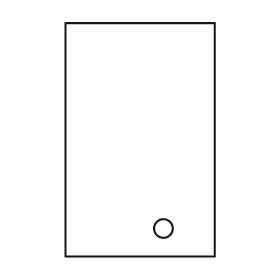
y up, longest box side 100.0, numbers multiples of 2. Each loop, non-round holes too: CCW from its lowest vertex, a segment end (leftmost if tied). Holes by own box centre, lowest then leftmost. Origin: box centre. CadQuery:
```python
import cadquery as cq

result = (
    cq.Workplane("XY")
    .moveTo(-32.0, -50.0)
    .lineTo(32.0, -50.0)
    .lineTo(32.0, 50.0)
    .lineTo(-32.0, 50.0)
    .close()
    .moveTo(10.0, -38.0)
    .circle(4.0)
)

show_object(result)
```